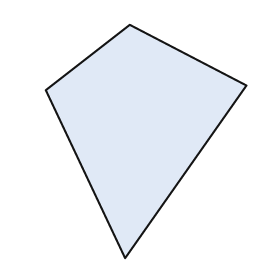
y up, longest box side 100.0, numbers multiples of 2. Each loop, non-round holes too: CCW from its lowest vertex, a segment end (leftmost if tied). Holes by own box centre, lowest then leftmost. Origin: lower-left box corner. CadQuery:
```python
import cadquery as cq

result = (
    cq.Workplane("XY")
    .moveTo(34.0, 0.0)
    .lineTo(86.0, 74.0)
    .lineTo(36.0, 100.0)
    .lineTo(0.0, 72.0)
    .close()
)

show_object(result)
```